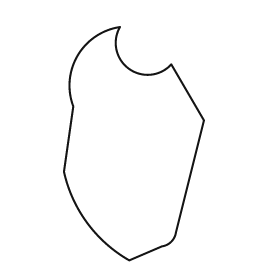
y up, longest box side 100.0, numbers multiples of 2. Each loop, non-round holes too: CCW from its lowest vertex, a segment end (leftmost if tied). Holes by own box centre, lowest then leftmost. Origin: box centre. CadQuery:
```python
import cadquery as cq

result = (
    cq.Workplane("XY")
    .moveTo(-2.0, -50.0)
    .lineTo(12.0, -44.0)
    .threePointArc((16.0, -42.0), (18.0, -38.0))
    .lineTo(30.0, 10.0)
    .lineTo(16.0, 34.0)
    .threePointArc((-2.0, 32.0), (-6.0, 50.0))
    .threePointArc((-24.0, 38.0), (-26.0, 16.0))
    .lineTo(-30.0, -12.0)
    .threePointArc((-20.0, -34.0), (-2.0, -50.0))
    .close()
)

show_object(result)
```